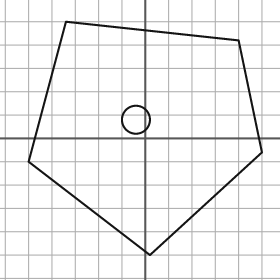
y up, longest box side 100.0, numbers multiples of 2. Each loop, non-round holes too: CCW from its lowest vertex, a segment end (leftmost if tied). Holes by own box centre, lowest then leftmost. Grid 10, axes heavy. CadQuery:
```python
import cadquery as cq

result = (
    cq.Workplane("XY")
    .moveTo(2.0, -50.0)
    .lineTo(50.0, -6.0)
    .lineTo(40.0, 42.0)
    .lineTo(-34.0, 50.0)
    .lineTo(-50.0, -10.0)
    .close()
    .moveTo(-4.0, 8.0)
    .circle(6.0)
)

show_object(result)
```